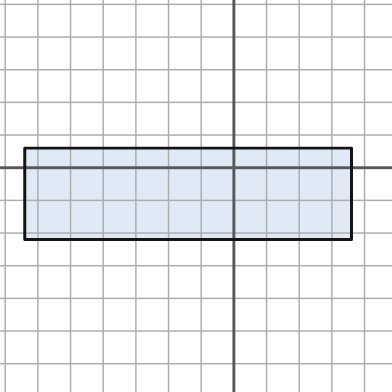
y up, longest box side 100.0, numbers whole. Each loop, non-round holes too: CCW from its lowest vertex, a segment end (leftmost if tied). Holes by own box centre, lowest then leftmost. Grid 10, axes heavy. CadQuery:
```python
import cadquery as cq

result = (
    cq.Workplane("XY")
    .moveTo(-64.0, -22.0)
    .lineTo(36.0, -22.0)
    .lineTo(36.0, 6.0)
    .lineTo(-64.0, 6.0)
    .close()
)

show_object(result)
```